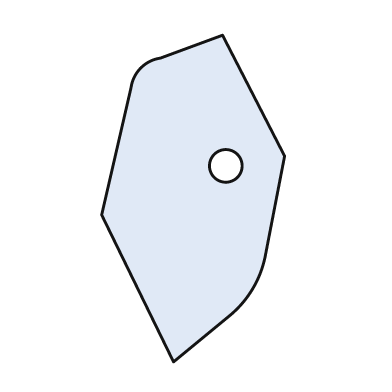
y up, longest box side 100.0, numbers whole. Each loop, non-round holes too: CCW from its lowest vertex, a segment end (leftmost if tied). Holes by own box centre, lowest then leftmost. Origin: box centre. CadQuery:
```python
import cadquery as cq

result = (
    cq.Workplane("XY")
    .moveTo(-6.0, -50.0)
    .lineTo(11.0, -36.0)
    .threePointArc((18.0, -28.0), (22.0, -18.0))
    .lineTo(28.0, 13.0)
    .lineTo(9.0, 50.0)
    .lineTo(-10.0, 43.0)
    .threePointArc((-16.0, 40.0), (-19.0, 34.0))
    .lineTo(-28.0, -5.0)
    .close()
    .moveTo(10.0, 10.0)
    .circle(5.0)
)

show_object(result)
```